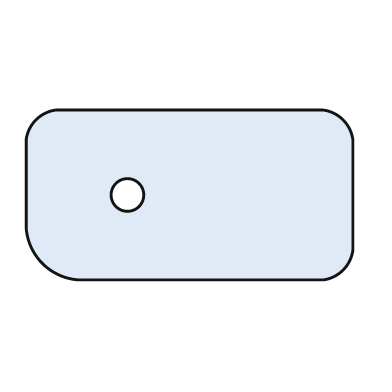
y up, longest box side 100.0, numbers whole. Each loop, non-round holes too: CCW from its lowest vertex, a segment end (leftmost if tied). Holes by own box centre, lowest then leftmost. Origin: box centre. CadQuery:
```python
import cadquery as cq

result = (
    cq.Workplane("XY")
    .moveTo(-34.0, -26.0)
    .lineTo(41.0, -26.0)
    .threePointArc((47.0, -23.0), (50.0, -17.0))
    .lineTo(50.0, 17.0)
    .threePointArc((47.0, 23.0), (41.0, 26.0))
    .lineTo(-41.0, 26.0)
    .threePointArc((-47.0, 23.0), (-50.0, 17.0))
    .lineTo(-50.0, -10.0)
    .threePointArc((-45.0, -21.0), (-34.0, -26.0))
    .close()
    .moveTo(-19.0, 0.0)
    .circle(5.0)
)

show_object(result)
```